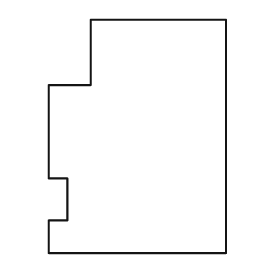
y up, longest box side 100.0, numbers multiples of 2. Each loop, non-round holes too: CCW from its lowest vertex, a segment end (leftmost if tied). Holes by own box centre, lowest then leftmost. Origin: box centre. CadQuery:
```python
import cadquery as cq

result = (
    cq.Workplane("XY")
    .moveTo(-38.0, -50.0)
    .lineTo(38.0, -50.0)
    .lineTo(38.0, 50.0)
    .lineTo(-20.0, 50.0)
    .lineTo(-20.0, 22.0)
    .lineTo(-38.0, 22.0)
    .lineTo(-38.0, -18.0)
    .lineTo(-30.0, -18.0)
    .lineTo(-30.0, -36.0)
    .lineTo(-38.0, -36.0)
    .close()
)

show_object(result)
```